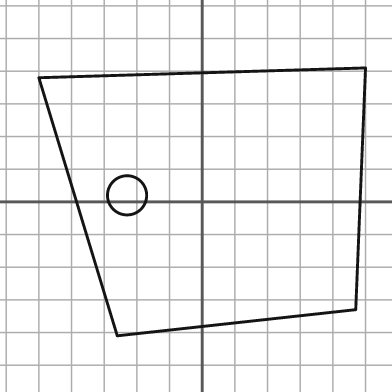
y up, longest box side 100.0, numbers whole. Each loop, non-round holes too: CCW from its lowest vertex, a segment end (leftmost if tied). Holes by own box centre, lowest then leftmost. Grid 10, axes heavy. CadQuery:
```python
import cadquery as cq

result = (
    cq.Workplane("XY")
    .moveTo(-26.0, -41.0)
    .lineTo(47.0, -33.0)
    .lineTo(50.0, 41.0)
    .lineTo(-50.0, 38.0)
    .close()
    .moveTo(-23.0, 2.0)
    .circle(6.0)
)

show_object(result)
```